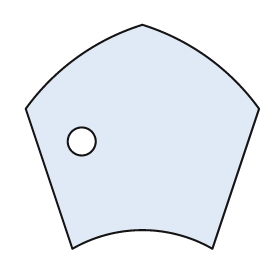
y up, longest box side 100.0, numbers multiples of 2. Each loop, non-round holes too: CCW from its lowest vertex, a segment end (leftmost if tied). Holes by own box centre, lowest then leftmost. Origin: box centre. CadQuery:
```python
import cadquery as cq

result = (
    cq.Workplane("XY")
    .moveTo(-30.0, -48.0)
    .threePointArc((0.0, -40.0), (30.0, -48.0))
    .lineTo(50.0, 12.0)
    .threePointArc((28.0, 34.0), (0.0, 48.0))
    .threePointArc((-28.0, 34.0), (-50.0, 12.0))
    .close()
    .moveTo(-26.0, -2.0)
    .circle(6.0)
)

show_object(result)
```